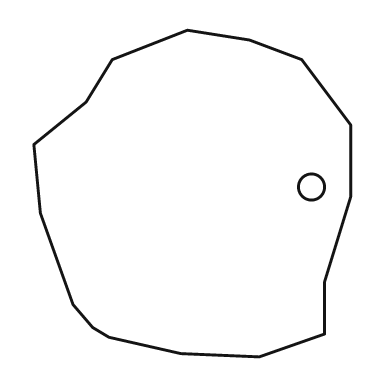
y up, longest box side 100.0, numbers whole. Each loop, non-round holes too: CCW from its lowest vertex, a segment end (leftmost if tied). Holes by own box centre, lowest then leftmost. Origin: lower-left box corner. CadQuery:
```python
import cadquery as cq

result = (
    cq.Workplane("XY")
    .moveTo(69.0, 0.0)
    .lineTo(89.0, 7.0)
    .lineTo(89.0, 23.0)
    .lineTo(97.0, 49.0)
    .lineTo(97.0, 71.0)
    .lineTo(82.0, 91.0)
    .lineTo(66.0, 97.0)
    .lineTo(47.0, 100.0)
    .lineTo(24.0, 91.0)
    .lineTo(16.0, 78.0)
    .lineTo(0.0, 65.0)
    .lineTo(2.0, 44.0)
    .lineTo(12.0, 16.0)
    .lineTo(18.0, 9.0)
    .lineTo(23.0, 6.0)
    .lineTo(45.0, 1.0)
    .close()
    .moveTo(85.0, 52.0)
    .circle(4.0)
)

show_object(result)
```